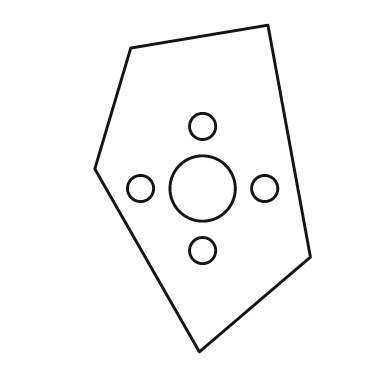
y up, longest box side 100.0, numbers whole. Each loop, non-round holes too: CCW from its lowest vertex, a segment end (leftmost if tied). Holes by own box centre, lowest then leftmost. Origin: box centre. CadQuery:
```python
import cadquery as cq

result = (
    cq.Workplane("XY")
    .moveTo(-1.0, -50.0)
    .lineTo(33.0, -21.0)
    .lineTo(20.0, 50.0)
    .lineTo(-22.0, 43.0)
    .lineTo(-33.0, 6.0)
    .close()
    .moveTo(0.0, -19.0)
    .circle(4.0)
    .moveTo(-19.0, 0.0)
    .circle(4.0)
    .moveTo(0.0, 0.0)
    .circle(10.0)
    .moveTo(19.0, 0.0)
    .circle(4.0)
    .moveTo(0.0, 19.0)
    .circle(4.0)
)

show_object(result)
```